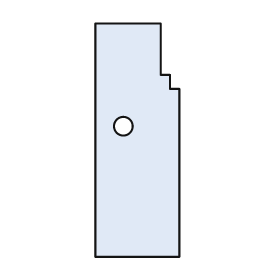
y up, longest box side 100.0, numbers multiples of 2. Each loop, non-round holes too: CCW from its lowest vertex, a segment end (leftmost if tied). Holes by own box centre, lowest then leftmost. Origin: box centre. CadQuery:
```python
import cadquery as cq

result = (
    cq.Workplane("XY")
    .moveTo(-18.0, -50.0)
    .lineTo(18.0, -50.0)
    .lineTo(18.0, 22.0)
    .lineTo(14.0, 22.0)
    .lineTo(14.0, 28.0)
    .lineTo(10.0, 28.0)
    .lineTo(10.0, 50.0)
    .lineTo(-18.0, 50.0)
    .close()
    .moveTo(-6.0, 6.0)
    .circle(4.0)
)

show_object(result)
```